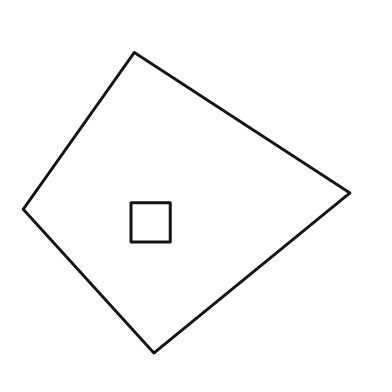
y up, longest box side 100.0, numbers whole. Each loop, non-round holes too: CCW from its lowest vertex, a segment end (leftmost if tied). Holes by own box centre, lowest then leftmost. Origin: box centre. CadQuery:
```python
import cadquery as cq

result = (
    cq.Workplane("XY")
    .moveTo(-10.0, -46.0)
    .lineTo(50.0, 3.0)
    .lineTo(-16.0, 46.0)
    .lineTo(-50.0, -2.0)
    .close()
    .moveTo(-17.0, -12.0)
    .lineTo(-5.0, -12.0)
    .lineTo(-5.0, 0.0)
    .lineTo(-17.0, 0.0)
    .close()
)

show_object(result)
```